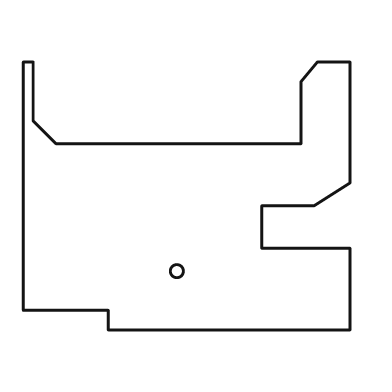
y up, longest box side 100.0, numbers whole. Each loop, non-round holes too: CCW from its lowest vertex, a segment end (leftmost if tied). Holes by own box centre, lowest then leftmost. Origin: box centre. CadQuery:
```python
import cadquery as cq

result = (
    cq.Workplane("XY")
    .moveTo(-24.0, -41.0)
    .lineTo(50.0, -41.0)
    .lineTo(50.0, -16.0)
    .lineTo(23.0, -16.0)
    .lineTo(23.0, -3.0)
    .lineTo(39.0, -3.0)
    .lineTo(50.0, 4.0)
    .lineTo(50.0, 41.0)
    .lineTo(40.0, 41.0)
    .lineTo(35.0, 35.0)
    .lineTo(35.0, 16.0)
    .lineTo(-40.0, 16.0)
    .lineTo(-47.0, 23.0)
    .lineTo(-47.0, 41.0)
    .lineTo(-50.0, 41.0)
    .lineTo(-50.0, -35.0)
    .lineTo(-24.0, -35.0)
    .close()
    .moveTo(-3.0, -23.0)
    .circle(2.0)
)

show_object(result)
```